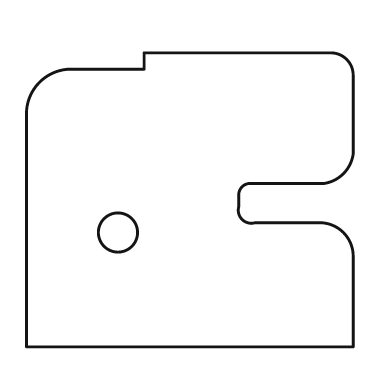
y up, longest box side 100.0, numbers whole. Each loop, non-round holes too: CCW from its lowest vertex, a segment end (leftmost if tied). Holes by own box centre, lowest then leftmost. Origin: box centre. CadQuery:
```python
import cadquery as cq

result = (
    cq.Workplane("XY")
    .moveTo(-50.0, -45.0)
    .lineTo(50.0, -45.0)
    .lineTo(50.0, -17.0)
    .threePointArc((47.0, -10.0), (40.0, -7.0))
    .lineTo(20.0, -7.0)
    .threePointArc((16.0, -6.0), (15.0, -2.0))
    .lineTo(15.0, 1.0)
    .threePointArc((16.0, 4.0), (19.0, 5.0))
    .lineTo(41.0, 5.0)
    .threePointArc((47.0, 8.0), (50.0, 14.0))
    .lineTo(50.0, 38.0)
    .threePointArc((48.0, 43.0), (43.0, 45.0))
    .lineTo(-14.0, 45.0)
    .lineTo(-14.0, 40.0)
    .lineTo(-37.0, 40.0)
    .threePointArc((-46.0, 36.0), (-50.0, 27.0))
    .close()
    .moveTo(-22.0, -10.0)
    .circle(6.0)
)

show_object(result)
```